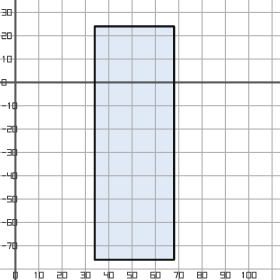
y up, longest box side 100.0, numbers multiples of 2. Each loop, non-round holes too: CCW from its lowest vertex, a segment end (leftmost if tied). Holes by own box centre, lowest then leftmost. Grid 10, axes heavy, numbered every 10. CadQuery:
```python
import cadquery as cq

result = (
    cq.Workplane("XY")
    .moveTo(34.0, -76.0)
    .lineTo(68.0, -76.0)
    .lineTo(68.0, 24.0)
    .lineTo(34.0, 24.0)
    .close()
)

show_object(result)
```